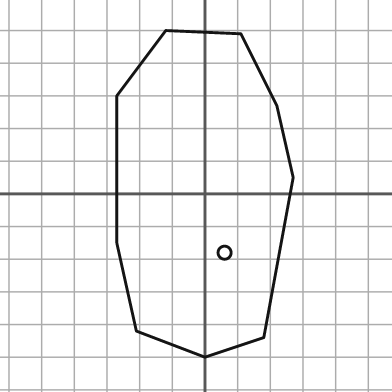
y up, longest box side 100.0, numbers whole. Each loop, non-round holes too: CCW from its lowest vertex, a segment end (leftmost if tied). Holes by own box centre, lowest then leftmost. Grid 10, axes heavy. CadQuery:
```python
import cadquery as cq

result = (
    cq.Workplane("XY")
    .moveTo(0.0, -50.0)
    .lineTo(18.0, -44.0)
    .lineTo(27.0, 5.0)
    .lineTo(22.0, 27.0)
    .lineTo(11.0, 49.0)
    .lineTo(-12.0, 50.0)
    .lineTo(-27.0, 30.0)
    .lineTo(-27.0, -15.0)
    .lineTo(-21.0, -42.0)
    .close()
    .moveTo(6.0, -18.0)
    .circle(2.0)
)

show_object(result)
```